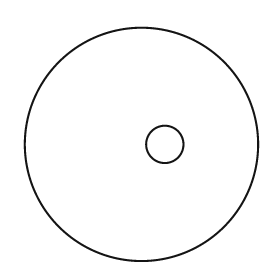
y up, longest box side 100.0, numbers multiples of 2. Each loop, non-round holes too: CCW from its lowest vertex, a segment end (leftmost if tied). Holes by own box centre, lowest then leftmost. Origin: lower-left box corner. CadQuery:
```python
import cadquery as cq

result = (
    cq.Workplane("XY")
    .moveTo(50.0, 50.0)
    .circle(50.0)
    .moveTo(60.0, 50.0)
    .circle(8.0)
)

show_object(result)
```